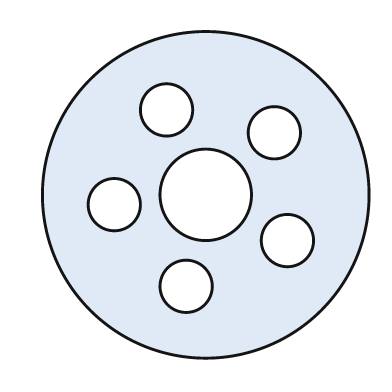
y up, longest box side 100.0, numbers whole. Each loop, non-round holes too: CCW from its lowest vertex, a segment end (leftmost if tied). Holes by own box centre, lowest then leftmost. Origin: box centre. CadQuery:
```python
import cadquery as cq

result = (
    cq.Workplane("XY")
    .moveTo(0.0, 0.0)
    .circle(50.0)
    .moveTo(-6.0, -28.0)
    .circle(8.0)
    .moveTo(25.0, -14.0)
    .circle(8.0)
    .moveTo(-28.0, -3.0)
    .circle(8.0)
    .moveTo(0.0, 0.0)
    .circle(14.0)
    .moveTo(21.0, 19.0)
    .circle(8.0)
    .moveTo(-12.0, 26.0)
    .circle(8.0)
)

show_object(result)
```